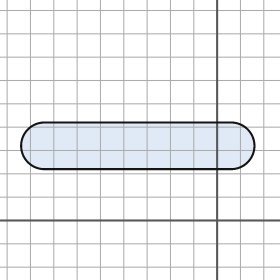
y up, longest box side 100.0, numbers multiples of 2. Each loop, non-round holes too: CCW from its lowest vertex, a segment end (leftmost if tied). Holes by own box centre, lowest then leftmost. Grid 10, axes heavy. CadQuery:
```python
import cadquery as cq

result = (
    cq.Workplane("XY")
    .moveTo(-74.0, 22.0)
    .lineTo(6.0, 22.0)
    .threePointArc((16.0, 32.0), (6.0, 42.0))
    .lineTo(-74.0, 42.0)
    .threePointArc((-84.0, 32.0), (-74.0, 22.0))
    .close()
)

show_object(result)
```